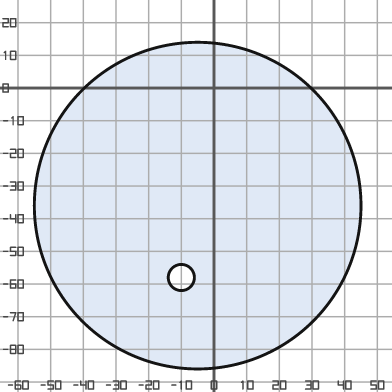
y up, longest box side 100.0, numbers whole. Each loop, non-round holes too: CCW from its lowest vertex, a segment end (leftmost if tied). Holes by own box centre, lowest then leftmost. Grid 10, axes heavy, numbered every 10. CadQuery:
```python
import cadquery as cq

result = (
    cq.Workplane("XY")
    .moveTo(-5.0, -36.0)
    .circle(50.0)
    .moveTo(-10.0, -58.0)
    .circle(4.0)
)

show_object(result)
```